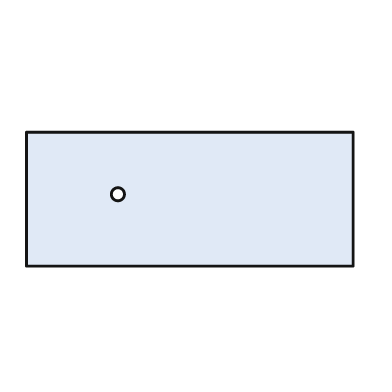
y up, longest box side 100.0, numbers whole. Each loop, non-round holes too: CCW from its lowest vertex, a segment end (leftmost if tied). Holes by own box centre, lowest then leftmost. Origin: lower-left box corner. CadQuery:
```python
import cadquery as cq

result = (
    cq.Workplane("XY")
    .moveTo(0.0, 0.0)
    .lineTo(100.0, 0.0)
    .lineTo(100.0, 41.0)
    .lineTo(0.0, 41.0)
    .close()
    .moveTo(28.0, 22.0)
    .circle(2.0)
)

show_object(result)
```